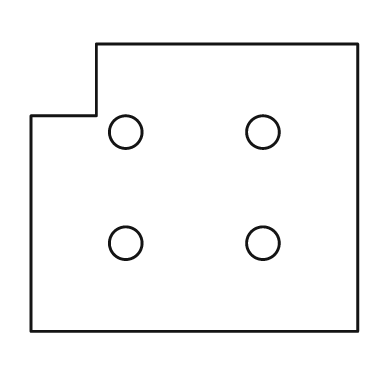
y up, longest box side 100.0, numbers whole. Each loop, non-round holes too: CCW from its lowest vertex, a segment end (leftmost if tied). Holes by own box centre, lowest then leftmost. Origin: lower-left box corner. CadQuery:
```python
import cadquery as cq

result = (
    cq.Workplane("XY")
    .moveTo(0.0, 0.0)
    .lineTo(100.0, 0.0)
    .lineTo(100.0, 88.0)
    .lineTo(20.0, 88.0)
    .lineTo(20.0, 66.0)
    .lineTo(0.0, 66.0)
    .close()
    .moveTo(29.0, 27.0)
    .circle(5.0)
    .moveTo(71.0, 27.0)
    .circle(5.0)
    .moveTo(29.0, 61.0)
    .circle(5.0)
    .moveTo(71.0, 61.0)
    .circle(5.0)
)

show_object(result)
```